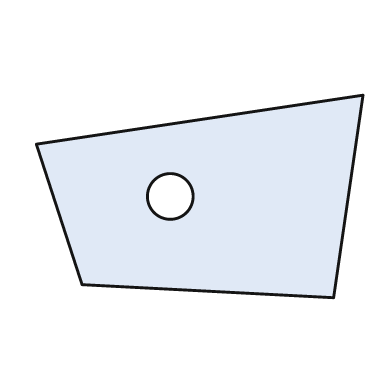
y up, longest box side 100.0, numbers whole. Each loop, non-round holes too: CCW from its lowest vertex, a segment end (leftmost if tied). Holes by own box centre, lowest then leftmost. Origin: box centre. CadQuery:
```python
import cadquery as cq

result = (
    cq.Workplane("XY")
    .moveTo(41.0, -31.0)
    .lineTo(50.0, 31.0)
    .lineTo(-50.0, 16.0)
    .lineTo(-36.0, -27.0)
    .close()
    .moveTo(-9.0, 0.0)
    .circle(7.0)
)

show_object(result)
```